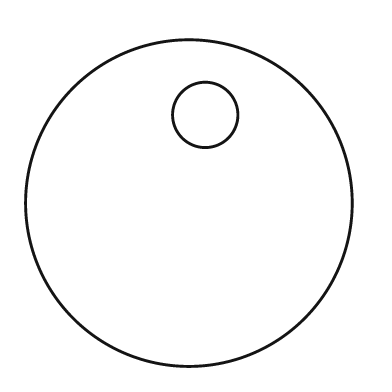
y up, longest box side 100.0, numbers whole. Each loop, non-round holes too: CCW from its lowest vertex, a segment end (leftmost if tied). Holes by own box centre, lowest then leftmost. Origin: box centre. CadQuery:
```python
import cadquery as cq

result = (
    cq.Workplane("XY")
    .moveTo(0.0, 0.0)
    .circle(50.0)
    .moveTo(5.0, 27.0)
    .circle(10.0)
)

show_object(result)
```